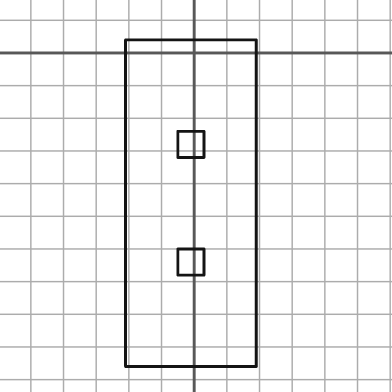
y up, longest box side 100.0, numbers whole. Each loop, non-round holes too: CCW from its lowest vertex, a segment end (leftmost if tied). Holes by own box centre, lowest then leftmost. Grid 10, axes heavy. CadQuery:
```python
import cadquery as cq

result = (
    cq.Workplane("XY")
    .moveTo(-21.0, -96.0)
    .lineTo(19.0, -96.0)
    .lineTo(19.0, 4.0)
    .lineTo(-21.0, 4.0)
    .close()
    .moveTo(-5.0, -68.0)
    .lineTo(3.0, -68.0)
    .lineTo(3.0, -60.0)
    .lineTo(-5.0, -60.0)
    .close()
    .moveTo(-5.0, -32.0)
    .lineTo(3.0, -32.0)
    .lineTo(3.0, -24.0)
    .lineTo(-5.0, -24.0)
    .close()
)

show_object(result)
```